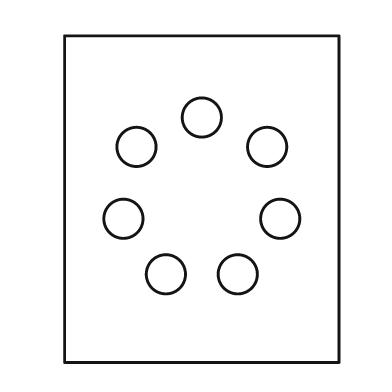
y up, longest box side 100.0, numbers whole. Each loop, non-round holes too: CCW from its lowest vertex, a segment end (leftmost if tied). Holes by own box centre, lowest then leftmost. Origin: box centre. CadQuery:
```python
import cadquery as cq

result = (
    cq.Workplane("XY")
    .moveTo(-42.0, -50.0)
    .lineTo(42.0, -50.0)
    .lineTo(42.0, 50.0)
    .lineTo(-42.0, 50.0)
    .close()
    .moveTo(-11.0, -23.0)
    .circle(6.0)
    .moveTo(11.0, -23.0)
    .circle(6.0)
    .moveTo(-24.0, -6.0)
    .circle(6.0)
    .moveTo(24.0, -6.0)
    .circle(6.0)
    .moveTo(-20.0, 16.0)
    .circle(6.0)
    .moveTo(20.0, 16.0)
    .circle(6.0)
    .moveTo(0.0, 25.0)
    .circle(6.0)
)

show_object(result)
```